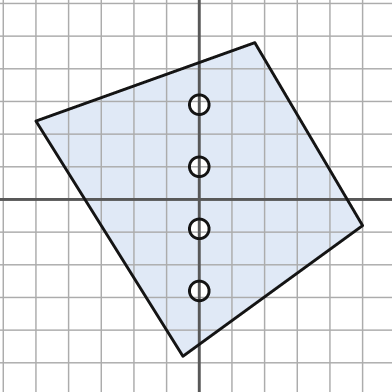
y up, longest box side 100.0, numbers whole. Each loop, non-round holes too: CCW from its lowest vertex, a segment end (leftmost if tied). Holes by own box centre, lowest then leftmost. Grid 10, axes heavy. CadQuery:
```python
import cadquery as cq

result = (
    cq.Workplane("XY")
    .moveTo(-5.0, -48.0)
    .lineTo(50.0, -8.0)
    .lineTo(17.0, 48.0)
    .lineTo(-50.0, 24.0)
    .close()
    .moveTo(0.0, -28.0)
    .circle(3.0)
    .moveTo(0.0, -9.0)
    .circle(3.0)
    .moveTo(0.0, 10.0)
    .circle(3.0)
    .moveTo(0.0, 29.0)
    .circle(3.0)
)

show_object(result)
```